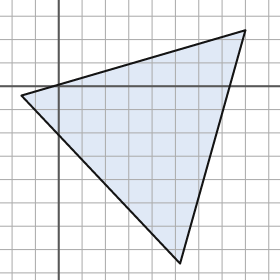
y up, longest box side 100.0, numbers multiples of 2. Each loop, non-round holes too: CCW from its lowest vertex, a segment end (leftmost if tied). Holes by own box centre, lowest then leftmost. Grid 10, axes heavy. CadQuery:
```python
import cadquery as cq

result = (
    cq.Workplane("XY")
    .moveTo(52.0, -76.0)
    .lineTo(80.0, 24.0)
    .lineTo(-16.0, -4.0)
    .close()
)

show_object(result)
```